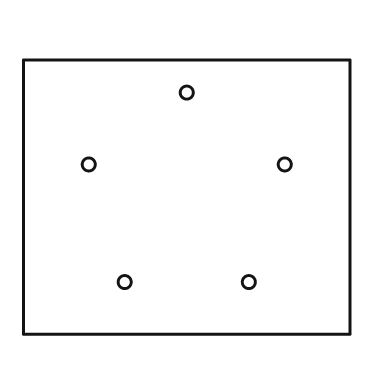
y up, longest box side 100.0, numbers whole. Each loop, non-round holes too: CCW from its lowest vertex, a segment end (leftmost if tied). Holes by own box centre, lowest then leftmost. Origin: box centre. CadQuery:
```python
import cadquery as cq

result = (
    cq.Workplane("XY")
    .moveTo(-50.0, -42.0)
    .lineTo(50.0, -42.0)
    .lineTo(50.0, 42.0)
    .lineTo(-50.0, 42.0)
    .close()
    .moveTo(-19.0, -26.0)
    .circle(2.0)
    .moveTo(19.0, -26.0)
    .circle(2.0)
    .moveTo(-30.0, 10.0)
    .circle(2.0)
    .moveTo(30.0, 10.0)
    .circle(2.0)
    .moveTo(0.0, 32.0)
    .circle(2.0)
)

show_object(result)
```